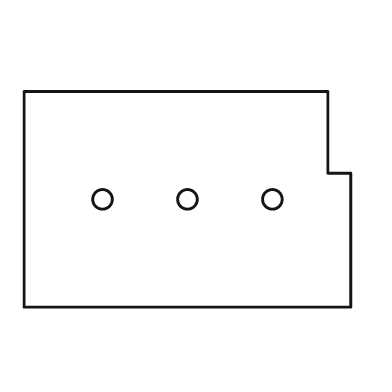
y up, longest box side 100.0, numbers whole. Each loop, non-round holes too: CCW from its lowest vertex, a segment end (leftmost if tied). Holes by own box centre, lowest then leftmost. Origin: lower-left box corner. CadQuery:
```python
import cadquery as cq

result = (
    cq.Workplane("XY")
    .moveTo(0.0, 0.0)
    .lineTo(100.0, 0.0)
    .lineTo(100.0, 41.0)
    .lineTo(93.0, 41.0)
    .lineTo(93.0, 66.0)
    .lineTo(0.0, 66.0)
    .close()
    .moveTo(24.0, 33.0)
    .circle(3.0)
    .moveTo(50.0, 33.0)
    .circle(3.0)
    .moveTo(76.0, 33.0)
    .circle(3.0)
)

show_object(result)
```